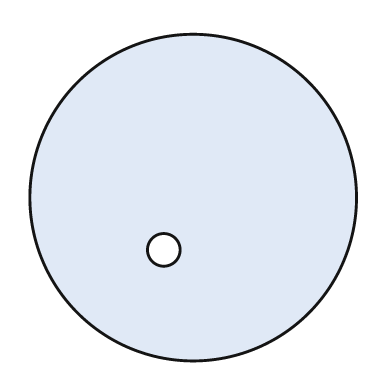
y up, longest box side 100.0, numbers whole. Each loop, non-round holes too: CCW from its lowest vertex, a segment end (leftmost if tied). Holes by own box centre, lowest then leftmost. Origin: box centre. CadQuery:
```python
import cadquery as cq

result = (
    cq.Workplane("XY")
    .moveTo(0.0, 0.0)
    .circle(50.0)
    .moveTo(-9.0, -16.0)
    .circle(5.0)
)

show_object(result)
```